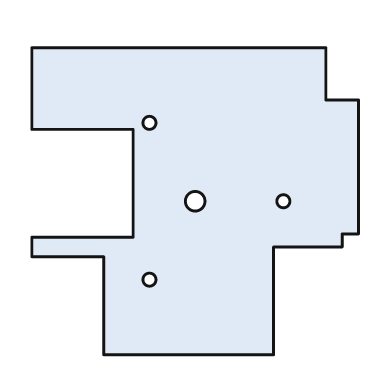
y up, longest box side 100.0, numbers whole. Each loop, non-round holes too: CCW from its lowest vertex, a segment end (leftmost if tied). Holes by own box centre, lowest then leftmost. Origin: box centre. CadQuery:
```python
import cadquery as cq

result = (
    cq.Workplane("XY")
    .moveTo(-28.0, -47.0)
    .lineTo(24.0, -47.0)
    .lineTo(24.0, -14.0)
    .lineTo(45.0, -14.0)
    .lineTo(45.0, -10.0)
    .lineTo(50.0, -10.0)
    .lineTo(50.0, 31.0)
    .lineTo(40.0, 31.0)
    .lineTo(40.0, 47.0)
    .lineTo(-50.0, 47.0)
    .lineTo(-50.0, 22.0)
    .lineTo(-19.0, 22.0)
    .lineTo(-19.0, -11.0)
    .lineTo(-50.0, -11.0)
    .lineTo(-50.0, -17.0)
    .lineTo(-28.0, -17.0)
    .close()
    .moveTo(-14.0, -24.0)
    .circle(2.0)
    .moveTo(0.0, 0.0)
    .circle(3.0)
    .moveTo(27.0, 0.0)
    .circle(2.0)
    .moveTo(-14.0, 24.0)
    .circle(2.0)
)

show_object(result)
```